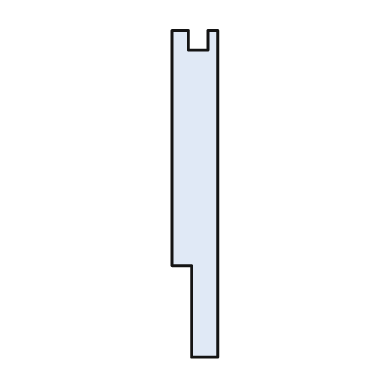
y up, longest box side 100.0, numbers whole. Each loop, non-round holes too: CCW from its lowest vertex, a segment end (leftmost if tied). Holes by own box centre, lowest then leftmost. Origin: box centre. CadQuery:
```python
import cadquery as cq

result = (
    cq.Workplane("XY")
    .moveTo(-1.0, -50.0)
    .lineTo(7.0, -50.0)
    .lineTo(7.0, 50.0)
    .lineTo(4.0, 50.0)
    .lineTo(4.0, 44.0)
    .lineTo(-2.0, 44.0)
    .lineTo(-2.0, 50.0)
    .lineTo(-7.0, 50.0)
    .lineTo(-7.0, -22.0)
    .lineTo(-1.0, -22.0)
    .close()
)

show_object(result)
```